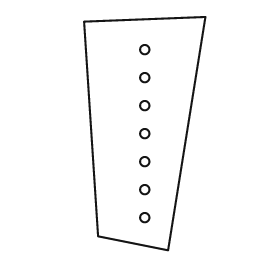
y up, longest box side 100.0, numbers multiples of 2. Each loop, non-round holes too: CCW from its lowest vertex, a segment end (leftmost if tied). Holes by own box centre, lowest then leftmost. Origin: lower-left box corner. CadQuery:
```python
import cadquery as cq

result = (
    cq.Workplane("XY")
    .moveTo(36.0, 0.0)
    .lineTo(52.0, 100.0)
    .lineTo(0.0, 98.0)
    .lineTo(6.0, 6.0)
    .close()
    .moveTo(26.0, 14.0)
    .circle(2.0)
    .moveTo(26.0, 26.0)
    .circle(2.0)
    .moveTo(26.0, 38.0)
    .circle(2.0)
    .moveTo(26.0, 50.0)
    .circle(2.0)
    .moveTo(26.0, 62.0)
    .circle(2.0)
    .moveTo(26.0, 74.0)
    .circle(2.0)
    .moveTo(26.0, 86.0)
    .circle(2.0)
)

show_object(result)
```